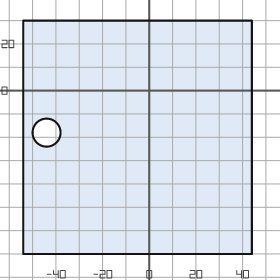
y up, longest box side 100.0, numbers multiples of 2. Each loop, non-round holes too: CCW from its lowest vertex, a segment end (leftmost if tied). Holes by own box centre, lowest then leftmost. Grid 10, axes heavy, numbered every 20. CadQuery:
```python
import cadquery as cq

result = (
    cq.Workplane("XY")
    .moveTo(-54.0, -70.0)
    .lineTo(44.0, -70.0)
    .lineTo(44.0, 30.0)
    .lineTo(-54.0, 30.0)
    .close()
    .moveTo(-44.0, -18.0)
    .circle(6.0)
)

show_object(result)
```